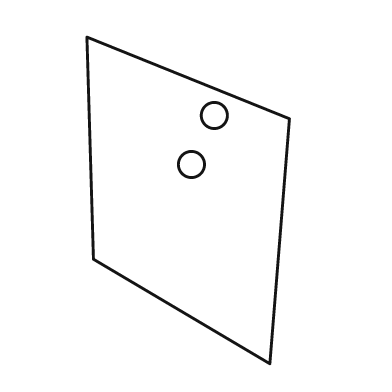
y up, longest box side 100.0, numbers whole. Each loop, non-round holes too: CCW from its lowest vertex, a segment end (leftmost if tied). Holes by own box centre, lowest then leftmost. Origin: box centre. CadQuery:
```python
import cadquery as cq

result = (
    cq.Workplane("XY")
    .moveTo(25.0, -50.0)
    .lineTo(31.0, 25.0)
    .lineTo(-31.0, 50.0)
    .lineTo(-29.0, -18.0)
    .close()
    .moveTo(1.0, 11.0)
    .circle(4.0)
    .moveTo(8.0, 26.0)
    .circle(4.0)
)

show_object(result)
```